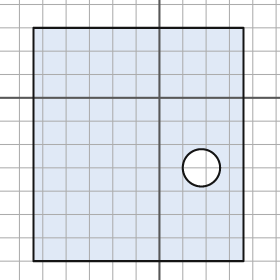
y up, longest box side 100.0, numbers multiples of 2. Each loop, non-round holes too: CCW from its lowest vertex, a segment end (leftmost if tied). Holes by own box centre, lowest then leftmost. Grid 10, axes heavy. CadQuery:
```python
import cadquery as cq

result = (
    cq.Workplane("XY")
    .moveTo(-54.0, -70.0)
    .lineTo(36.0, -70.0)
    .lineTo(36.0, 30.0)
    .lineTo(-54.0, 30.0)
    .close()
    .moveTo(18.0, -30.0)
    .circle(8.0)
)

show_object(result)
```